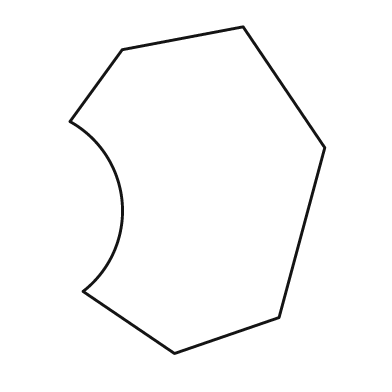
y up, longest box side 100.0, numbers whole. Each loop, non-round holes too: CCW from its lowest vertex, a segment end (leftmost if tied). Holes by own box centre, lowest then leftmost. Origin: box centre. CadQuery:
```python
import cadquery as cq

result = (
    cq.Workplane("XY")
    .moveTo(-7.0, -50.0)
    .lineTo(25.0, -39.0)
    .lineTo(39.0, 13.0)
    .lineTo(14.0, 50.0)
    .lineTo(-23.0, 43.0)
    .lineTo(-39.0, 21.0)
    .threePointArc((-23.0, -4.0), (-35.0, -31.0))
    .close()
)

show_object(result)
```